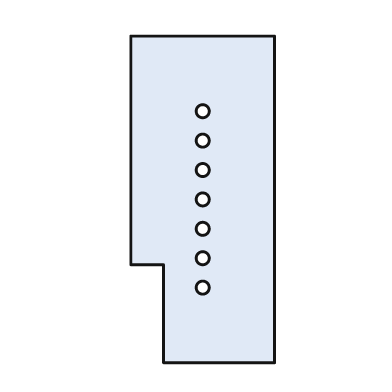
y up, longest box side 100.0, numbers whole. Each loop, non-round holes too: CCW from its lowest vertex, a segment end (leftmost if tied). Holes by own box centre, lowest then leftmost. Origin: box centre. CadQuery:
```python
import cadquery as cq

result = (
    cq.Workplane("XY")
    .moveTo(-12.0, -50.0)
    .lineTo(22.0, -50.0)
    .lineTo(22.0, 50.0)
    .lineTo(-22.0, 50.0)
    .lineTo(-22.0, -20.0)
    .lineTo(-12.0, -20.0)
    .close()
    .moveTo(0.0, -27.0)
    .circle(2.0)
    .moveTo(0.0, -18.0)
    .circle(2.0)
    .moveTo(0.0, -9.0)
    .circle(2.0)
    .moveTo(0.0, 0.0)
    .circle(2.0)
    .moveTo(0.0, 9.0)
    .circle(2.0)
    .moveTo(0.0, 18.0)
    .circle(2.0)
    .moveTo(0.0, 27.0)
    .circle(2.0)
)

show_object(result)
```